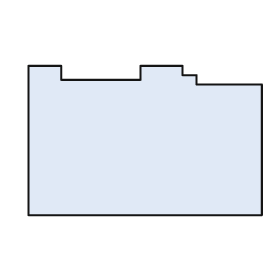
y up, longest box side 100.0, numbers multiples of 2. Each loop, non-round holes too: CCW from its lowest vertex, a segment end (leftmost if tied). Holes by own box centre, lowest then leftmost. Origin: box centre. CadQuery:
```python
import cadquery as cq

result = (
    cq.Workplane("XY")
    .moveTo(-50.0, -32.0)
    .lineTo(50.0, -32.0)
    .lineTo(50.0, 24.0)
    .lineTo(22.0, 24.0)
    .lineTo(22.0, 28.0)
    .lineTo(16.0, 28.0)
    .lineTo(16.0, 32.0)
    .lineTo(-2.0, 32.0)
    .lineTo(-2.0, 26.0)
    .lineTo(-36.0, 26.0)
    .lineTo(-36.0, 32.0)
    .lineTo(-50.0, 32.0)
    .close()
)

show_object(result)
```